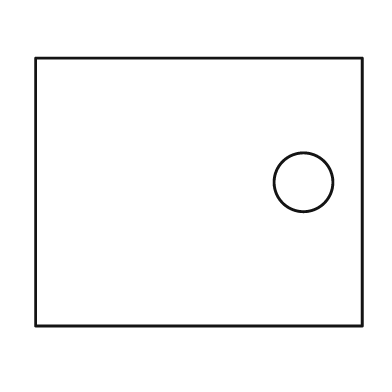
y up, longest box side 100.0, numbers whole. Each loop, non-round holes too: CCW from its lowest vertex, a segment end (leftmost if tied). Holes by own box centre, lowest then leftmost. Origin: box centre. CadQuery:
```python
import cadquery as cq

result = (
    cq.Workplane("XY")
    .moveTo(-50.0, -41.0)
    .lineTo(50.0, -41.0)
    .lineTo(50.0, 41.0)
    .lineTo(-50.0, 41.0)
    .close()
    .moveTo(32.0, 3.0)
    .circle(9.0)
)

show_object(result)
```